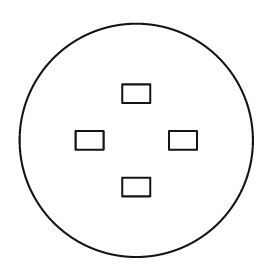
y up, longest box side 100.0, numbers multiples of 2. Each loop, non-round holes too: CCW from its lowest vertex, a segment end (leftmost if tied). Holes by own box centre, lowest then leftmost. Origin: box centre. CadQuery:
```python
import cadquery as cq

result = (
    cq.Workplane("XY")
    .moveTo(0.0, 0.0)
    .circle(50.0)
    .moveTo(-6.0, -24.0)
    .lineTo(6.0, -24.0)
    .lineTo(6.0, -16.0)
    .lineTo(-6.0, -16.0)
    .close()
    .moveTo(-26.0, -4.0)
    .lineTo(-14.0, -4.0)
    .lineTo(-14.0, 4.0)
    .lineTo(-26.0, 4.0)
    .close()
    .moveTo(14.0, -4.0)
    .lineTo(26.0, -4.0)
    .lineTo(26.0, 4.0)
    .lineTo(14.0, 4.0)
    .close()
    .moveTo(-6.0, 16.0)
    .lineTo(6.0, 16.0)
    .lineTo(6.0, 24.0)
    .lineTo(-6.0, 24.0)
    .close()
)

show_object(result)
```